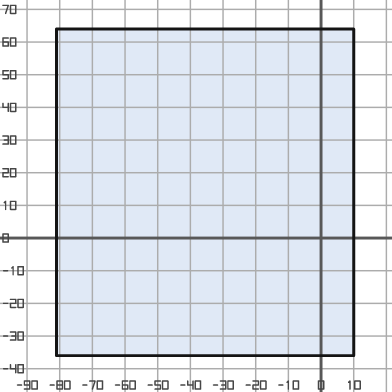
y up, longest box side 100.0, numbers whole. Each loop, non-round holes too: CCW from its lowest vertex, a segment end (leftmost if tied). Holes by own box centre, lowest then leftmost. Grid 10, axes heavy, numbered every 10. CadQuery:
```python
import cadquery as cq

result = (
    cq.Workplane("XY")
    .moveTo(-81.0, -36.0)
    .lineTo(10.0, -36.0)
    .lineTo(10.0, 64.0)
    .lineTo(-81.0, 64.0)
    .close()
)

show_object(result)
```